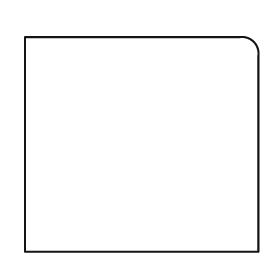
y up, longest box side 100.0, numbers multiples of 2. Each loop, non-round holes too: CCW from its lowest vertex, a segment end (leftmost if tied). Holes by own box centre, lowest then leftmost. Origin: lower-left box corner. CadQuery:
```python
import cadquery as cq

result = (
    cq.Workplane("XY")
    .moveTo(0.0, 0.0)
    .lineTo(100.0, 0.0)
    .lineTo(100.0, 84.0)
    .threePointArc((98.0, 90.0), (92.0, 92.0))
    .lineTo(0.0, 92.0)
    .close()
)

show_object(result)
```